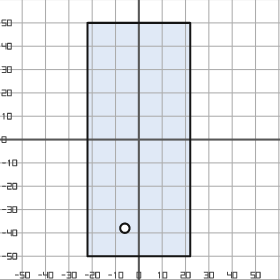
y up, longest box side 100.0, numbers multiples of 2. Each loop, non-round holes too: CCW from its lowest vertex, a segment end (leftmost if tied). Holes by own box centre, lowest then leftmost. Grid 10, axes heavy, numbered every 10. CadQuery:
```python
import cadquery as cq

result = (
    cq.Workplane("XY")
    .moveTo(-22.0, -50.0)
    .lineTo(22.0, -50.0)
    .lineTo(22.0, 50.0)
    .lineTo(-22.0, 50.0)
    .close()
    .moveTo(-6.0, -38.0)
    .circle(2.0)
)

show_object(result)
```